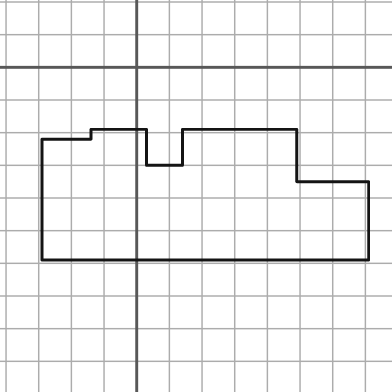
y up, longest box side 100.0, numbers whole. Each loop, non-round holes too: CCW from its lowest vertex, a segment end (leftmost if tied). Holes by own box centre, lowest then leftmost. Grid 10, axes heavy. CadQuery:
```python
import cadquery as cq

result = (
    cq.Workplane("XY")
    .moveTo(-29.0, -59.0)
    .lineTo(71.0, -59.0)
    .lineTo(71.0, -35.0)
    .lineTo(49.0, -35.0)
    .lineTo(49.0, -19.0)
    .lineTo(14.0, -19.0)
    .lineTo(14.0, -30.0)
    .lineTo(3.0, -30.0)
    .lineTo(3.0, -19.0)
    .lineTo(-14.0, -19.0)
    .lineTo(-14.0, -22.0)
    .lineTo(-29.0, -22.0)
    .close()
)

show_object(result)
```